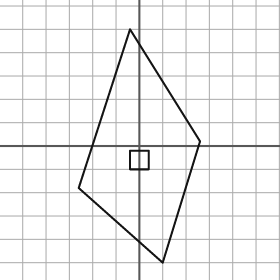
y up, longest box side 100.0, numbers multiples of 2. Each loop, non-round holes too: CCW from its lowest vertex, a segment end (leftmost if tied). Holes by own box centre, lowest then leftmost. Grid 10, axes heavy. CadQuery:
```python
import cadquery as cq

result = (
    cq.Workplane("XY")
    .moveTo(10.0, -50.0)
    .lineTo(26.0, 2.0)
    .lineTo(-4.0, 50.0)
    .lineTo(-26.0, -18.0)
    .close()
    .moveTo(-4.0, -10.0)
    .lineTo(4.0, -10.0)
    .lineTo(4.0, -2.0)
    .lineTo(-4.0, -2.0)
    .close()
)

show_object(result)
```